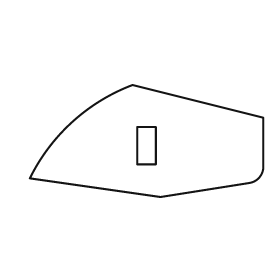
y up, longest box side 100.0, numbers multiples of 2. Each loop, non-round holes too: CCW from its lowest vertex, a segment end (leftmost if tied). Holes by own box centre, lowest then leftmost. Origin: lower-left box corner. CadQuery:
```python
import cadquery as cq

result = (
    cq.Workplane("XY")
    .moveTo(56.0, 0.0)
    .lineTo(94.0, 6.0)
    .threePointArc((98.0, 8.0), (100.0, 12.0))
    .lineTo(100.0, 34.0)
    .lineTo(44.0, 48.0)
    .threePointArc((18.0, 32.0), (0.0, 8.0))
    .close()
    .moveTo(46.0, 14.0)
    .lineTo(54.0, 14.0)
    .lineTo(54.0, 30.0)
    .lineTo(46.0, 30.0)
    .close()
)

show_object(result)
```